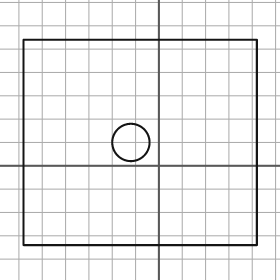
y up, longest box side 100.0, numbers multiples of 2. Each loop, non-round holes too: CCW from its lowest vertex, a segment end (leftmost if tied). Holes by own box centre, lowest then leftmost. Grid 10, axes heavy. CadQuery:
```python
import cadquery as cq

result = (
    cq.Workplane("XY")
    .moveTo(-58.0, -34.0)
    .lineTo(42.0, -34.0)
    .lineTo(42.0, 54.0)
    .lineTo(-58.0, 54.0)
    .close()
    .moveTo(-12.0, 10.0)
    .circle(8.0)
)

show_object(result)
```